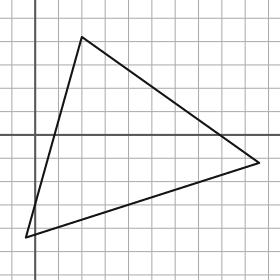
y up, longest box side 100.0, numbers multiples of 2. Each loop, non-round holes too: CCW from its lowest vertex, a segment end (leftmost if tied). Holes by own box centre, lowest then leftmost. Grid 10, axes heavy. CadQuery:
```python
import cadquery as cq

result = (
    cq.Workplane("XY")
    .moveTo(-4.0, -44.0)
    .lineTo(96.0, -12.0)
    .lineTo(20.0, 42.0)
    .close()
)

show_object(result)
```